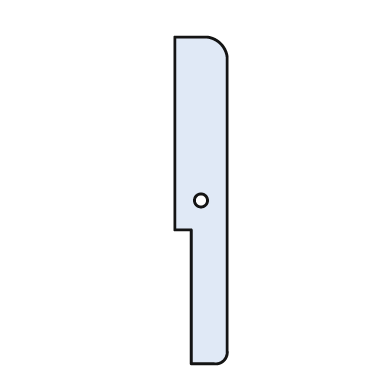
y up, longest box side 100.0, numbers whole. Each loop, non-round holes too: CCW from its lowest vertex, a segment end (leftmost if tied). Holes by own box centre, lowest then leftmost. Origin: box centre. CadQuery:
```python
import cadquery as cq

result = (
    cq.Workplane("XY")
    .moveTo(-3.0, -50.0)
    .lineTo(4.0, -50.0)
    .threePointArc((7.0, -49.0), (8.0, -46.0))
    .lineTo(8.0, 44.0)
    .threePointArc((6.0, 48.0), (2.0, 50.0))
    .lineTo(-8.0, 50.0)
    .lineTo(-8.0, -9.0)
    .lineTo(-3.0, -9.0)
    .close()
    .moveTo(0.0, 0.0)
    .circle(2.0)
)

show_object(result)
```